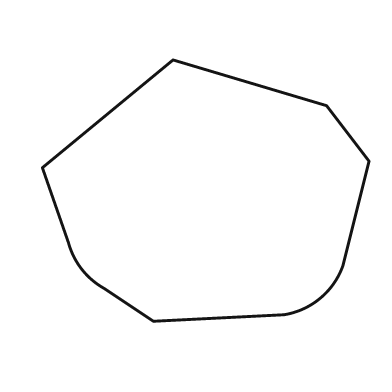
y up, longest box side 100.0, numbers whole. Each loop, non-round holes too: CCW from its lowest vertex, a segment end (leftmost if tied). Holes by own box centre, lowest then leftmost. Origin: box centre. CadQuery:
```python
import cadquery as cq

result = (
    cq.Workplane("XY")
    .moveTo(-16.0, -40.0)
    .lineTo(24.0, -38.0)
    .threePointArc((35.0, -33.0), (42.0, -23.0))
    .lineTo(50.0, 9.0)
    .lineTo(37.0, 26.0)
    .lineTo(-10.0, 40.0)
    .lineTo(-50.0, 7.0)
    .lineTo(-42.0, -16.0)
    .threePointArc((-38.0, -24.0), (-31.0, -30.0))
    .close()
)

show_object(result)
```